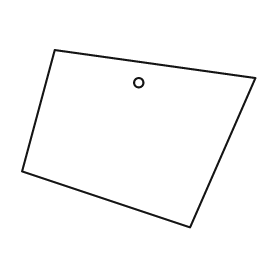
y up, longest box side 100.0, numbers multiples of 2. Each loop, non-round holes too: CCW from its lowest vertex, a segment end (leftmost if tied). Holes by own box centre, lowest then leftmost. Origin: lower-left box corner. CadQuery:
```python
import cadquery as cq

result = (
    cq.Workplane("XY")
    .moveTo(72.0, 0.0)
    .lineTo(100.0, 64.0)
    .lineTo(14.0, 76.0)
    .lineTo(0.0, 24.0)
    .close()
    .moveTo(50.0, 62.0)
    .circle(2.0)
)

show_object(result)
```